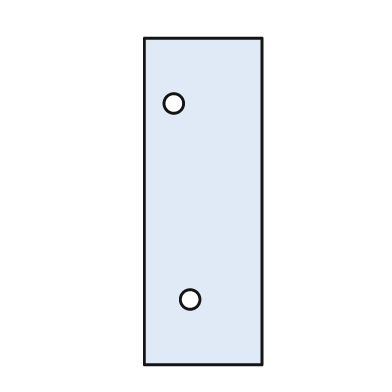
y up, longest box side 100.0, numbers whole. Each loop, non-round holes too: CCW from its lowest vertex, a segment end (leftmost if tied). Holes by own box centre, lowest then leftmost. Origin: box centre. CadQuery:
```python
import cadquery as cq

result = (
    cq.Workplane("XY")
    .moveTo(-18.0, -50.0)
    .lineTo(18.0, -50.0)
    .lineTo(18.0, 50.0)
    .lineTo(-18.0, 50.0)
    .close()
    .moveTo(-4.0, -30.0)
    .circle(3.0)
    .moveTo(-9.0, 30.0)
    .circle(3.0)
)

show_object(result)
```